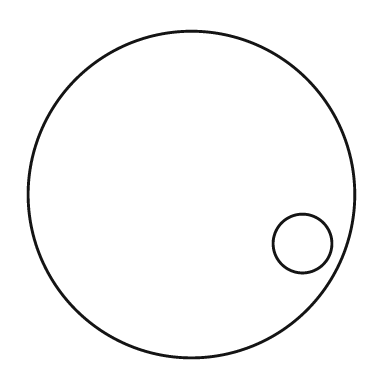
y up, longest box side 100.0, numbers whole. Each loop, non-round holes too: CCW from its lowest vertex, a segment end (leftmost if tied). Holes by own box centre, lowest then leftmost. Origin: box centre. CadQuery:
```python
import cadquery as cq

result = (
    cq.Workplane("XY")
    .moveTo(0.0, 0.0)
    .circle(50.0)
    .moveTo(34.0, -15.0)
    .circle(9.0)
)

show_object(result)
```